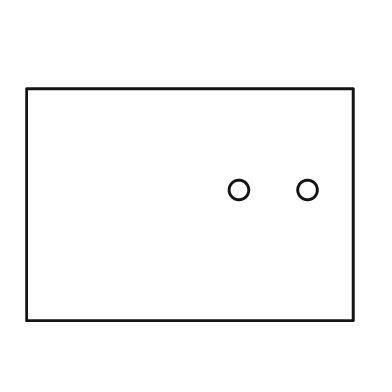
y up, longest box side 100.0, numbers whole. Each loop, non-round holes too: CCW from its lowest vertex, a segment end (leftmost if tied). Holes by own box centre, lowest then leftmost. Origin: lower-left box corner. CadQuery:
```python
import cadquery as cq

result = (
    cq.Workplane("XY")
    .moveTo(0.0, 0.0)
    .lineTo(100.0, 0.0)
    .lineTo(100.0, 71.0)
    .lineTo(0.0, 71.0)
    .close()
    .moveTo(65.0, 40.0)
    .circle(3.0)
    .moveTo(86.0, 40.0)
    .circle(3.0)
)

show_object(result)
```